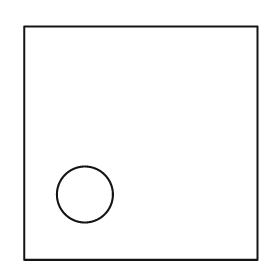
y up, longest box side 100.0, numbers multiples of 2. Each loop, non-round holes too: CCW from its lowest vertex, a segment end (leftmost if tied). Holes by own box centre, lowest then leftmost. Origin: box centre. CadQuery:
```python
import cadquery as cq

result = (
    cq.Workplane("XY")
    .moveTo(-50.0, -50.0)
    .lineTo(50.0, -50.0)
    .lineTo(50.0, 50.0)
    .lineTo(-50.0, 50.0)
    .close()
    .moveTo(-24.0, -22.0)
    .circle(12.0)
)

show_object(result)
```